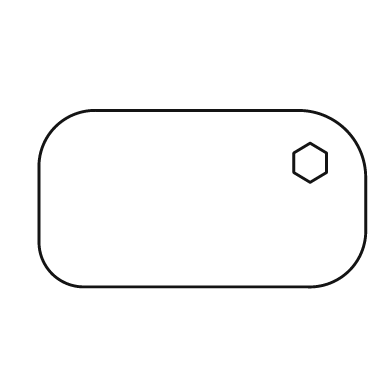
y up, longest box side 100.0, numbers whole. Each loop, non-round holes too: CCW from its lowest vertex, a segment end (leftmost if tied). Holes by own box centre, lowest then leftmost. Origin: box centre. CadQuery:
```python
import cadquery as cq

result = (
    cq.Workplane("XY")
    .moveTo(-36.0, -27.0)
    .lineTo(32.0, -27.0)
    .threePointArc((45.0, -22.0), (50.0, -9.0))
    .lineTo(50.0, 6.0)
    .threePointArc((44.0, 21.0), (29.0, 27.0))
    .lineTo(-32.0, 27.0)
    .threePointArc((-45.0, 22.0), (-50.0, 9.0))
    .lineTo(-50.0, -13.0)
    .threePointArc((-46.0, -23.0), (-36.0, -27.0))
    .close()
    .moveTo(33.0, 5.0)
    .lineTo(38.0, 8.0)
    .lineTo(38.0, 14.0)
    .lineTo(33.0, 17.0)
    .lineTo(28.0, 14.0)
    .lineTo(28.0, 8.0)
    .close()
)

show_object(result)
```